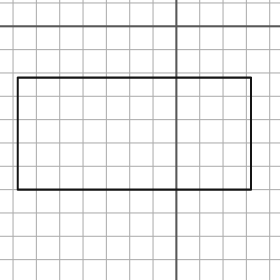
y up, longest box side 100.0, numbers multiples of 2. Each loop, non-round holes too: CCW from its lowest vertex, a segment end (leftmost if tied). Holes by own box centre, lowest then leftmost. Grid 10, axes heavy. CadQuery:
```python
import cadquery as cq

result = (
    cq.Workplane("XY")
    .moveTo(-68.0, -70.0)
    .lineTo(32.0, -70.0)
    .lineTo(32.0, -22.0)
    .lineTo(-68.0, -22.0)
    .close()
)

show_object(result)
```